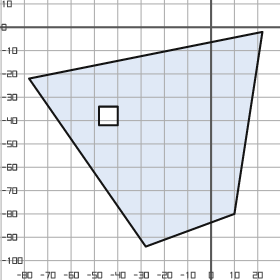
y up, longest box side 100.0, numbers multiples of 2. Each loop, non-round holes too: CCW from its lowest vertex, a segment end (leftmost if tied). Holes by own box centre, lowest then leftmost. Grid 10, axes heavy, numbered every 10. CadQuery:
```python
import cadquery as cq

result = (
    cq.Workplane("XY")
    .moveTo(-28.0, -94.0)
    .lineTo(10.0, -80.0)
    .lineTo(22.0, -2.0)
    .lineTo(-78.0, -22.0)
    .close()
    .moveTo(-48.0, -42.0)
    .lineTo(-40.0, -42.0)
    .lineTo(-40.0, -34.0)
    .lineTo(-48.0, -34.0)
    .close()
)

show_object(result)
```